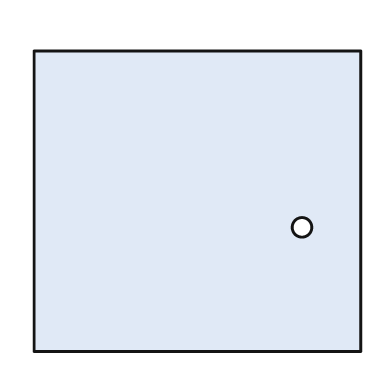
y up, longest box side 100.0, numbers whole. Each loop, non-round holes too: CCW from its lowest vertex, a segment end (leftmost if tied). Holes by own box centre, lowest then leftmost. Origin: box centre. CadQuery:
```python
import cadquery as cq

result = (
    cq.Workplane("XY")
    .moveTo(-50.0, -46.0)
    .lineTo(50.0, -46.0)
    .lineTo(50.0, 46.0)
    .lineTo(-50.0, 46.0)
    .close()
    .moveTo(32.0, -8.0)
    .circle(3.0)
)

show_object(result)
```